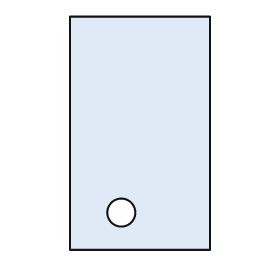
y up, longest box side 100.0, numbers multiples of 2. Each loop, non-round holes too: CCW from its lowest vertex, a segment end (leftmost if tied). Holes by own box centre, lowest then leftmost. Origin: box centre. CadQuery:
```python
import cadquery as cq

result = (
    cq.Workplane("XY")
    .moveTo(-30.0, -50.0)
    .lineTo(30.0, -50.0)
    .lineTo(30.0, 50.0)
    .lineTo(-30.0, 50.0)
    .close()
    .moveTo(-8.0, -34.0)
    .circle(6.0)
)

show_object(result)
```